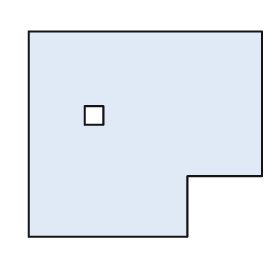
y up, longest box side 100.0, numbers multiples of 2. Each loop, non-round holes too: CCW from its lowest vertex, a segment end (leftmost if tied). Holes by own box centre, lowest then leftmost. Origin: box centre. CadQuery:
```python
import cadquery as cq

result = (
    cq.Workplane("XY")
    .moveTo(-50.0, -44.0)
    .lineTo(18.0, -44.0)
    .lineTo(18.0, -18.0)
    .lineTo(50.0, -18.0)
    .lineTo(50.0, 44.0)
    .lineTo(-50.0, 44.0)
    .close()
    .moveTo(-26.0, 4.0)
    .lineTo(-18.0, 4.0)
    .lineTo(-18.0, 12.0)
    .lineTo(-26.0, 12.0)
    .close()
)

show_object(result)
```